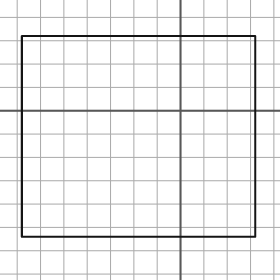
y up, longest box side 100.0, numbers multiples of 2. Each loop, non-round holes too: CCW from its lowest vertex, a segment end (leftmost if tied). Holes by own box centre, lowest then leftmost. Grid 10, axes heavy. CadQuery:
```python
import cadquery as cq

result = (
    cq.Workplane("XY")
    .moveTo(-68.0, -54.0)
    .lineTo(32.0, -54.0)
    .lineTo(32.0, 32.0)
    .lineTo(-68.0, 32.0)
    .close()
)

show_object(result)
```